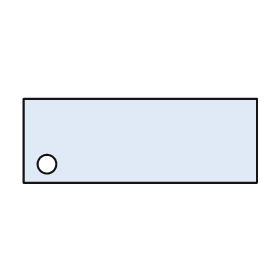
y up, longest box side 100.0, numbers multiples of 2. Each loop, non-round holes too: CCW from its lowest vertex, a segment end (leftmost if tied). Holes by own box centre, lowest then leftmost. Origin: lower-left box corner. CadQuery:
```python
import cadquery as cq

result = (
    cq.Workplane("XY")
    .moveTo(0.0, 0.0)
    .lineTo(100.0, 0.0)
    .lineTo(100.0, 36.0)
    .lineTo(0.0, 36.0)
    .close()
    .moveTo(10.0, 8.0)
    .circle(4.0)
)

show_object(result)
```